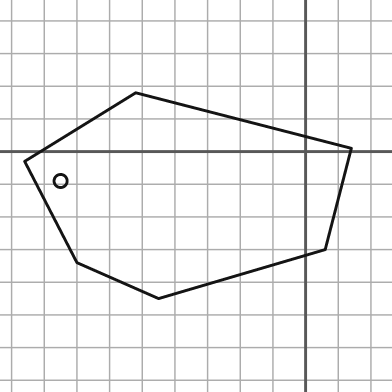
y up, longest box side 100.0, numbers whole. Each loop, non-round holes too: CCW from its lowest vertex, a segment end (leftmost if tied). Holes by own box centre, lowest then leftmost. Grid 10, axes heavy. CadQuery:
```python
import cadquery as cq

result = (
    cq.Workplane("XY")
    .moveTo(-45.0, -45.0)
    .lineTo(6.0, -30.0)
    .lineTo(14.0, 1.0)
    .lineTo(-52.0, 18.0)
    .lineTo(-86.0, -3.0)
    .lineTo(-70.0, -34.0)
    .close()
    .moveTo(-75.0, -9.0)
    .circle(2.0)
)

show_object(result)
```